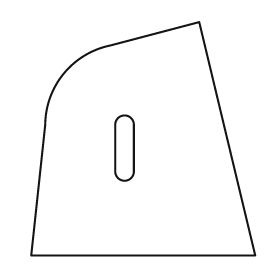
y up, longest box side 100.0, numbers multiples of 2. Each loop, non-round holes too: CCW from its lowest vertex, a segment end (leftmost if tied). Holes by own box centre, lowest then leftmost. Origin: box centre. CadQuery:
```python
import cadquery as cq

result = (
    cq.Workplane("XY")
    .moveTo(-48.0, -50.0)
    .lineTo(48.0, -50.0)
    .lineTo(24.0, 50.0)
    .lineTo(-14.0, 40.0)
    .threePointArc((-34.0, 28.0), (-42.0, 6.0))
    .close()
    .moveTo(-12.0, -14.0)
    .threePointArc((-8.0, -18.0), (-4.0, -14.0))
    .lineTo(-4.0, 6.0)
    .threePointArc((-8.0, 10.0), (-12.0, 6.0))
    .close()
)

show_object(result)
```